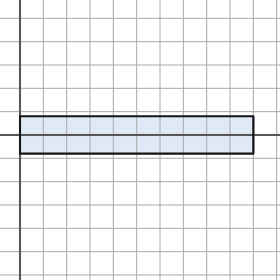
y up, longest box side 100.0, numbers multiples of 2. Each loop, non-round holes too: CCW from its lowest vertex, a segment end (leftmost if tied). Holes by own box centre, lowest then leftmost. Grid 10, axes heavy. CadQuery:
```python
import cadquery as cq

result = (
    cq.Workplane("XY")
    .moveTo(0.0, -8.0)
    .lineTo(100.0, -8.0)
    .lineTo(100.0, 8.0)
    .lineTo(0.0, 8.0)
    .close()
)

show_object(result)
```